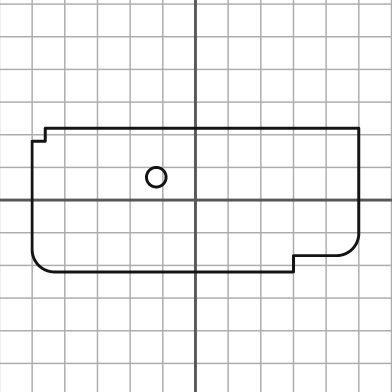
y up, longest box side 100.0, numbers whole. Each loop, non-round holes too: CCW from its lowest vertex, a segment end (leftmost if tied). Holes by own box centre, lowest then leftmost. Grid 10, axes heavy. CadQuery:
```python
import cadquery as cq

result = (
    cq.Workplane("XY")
    .moveTo(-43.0, -22.0)
    .lineTo(30.0, -22.0)
    .lineTo(30.0, -17.0)
    .lineTo(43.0, -17.0)
    .threePointArc((48.0, -15.0), (50.0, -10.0))
    .lineTo(50.0, 22.0)
    .lineTo(-46.0, 22.0)
    .lineTo(-46.0, 18.0)
    .lineTo(-50.0, 18.0)
    .lineTo(-50.0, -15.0)
    .threePointArc((-48.0, -20.0), (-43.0, -22.0))
    .close()
    .moveTo(-12.0, 7.0)
    .circle(3.0)
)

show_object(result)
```